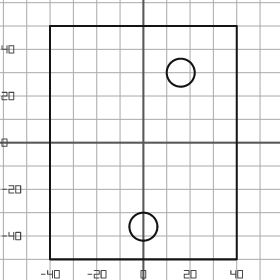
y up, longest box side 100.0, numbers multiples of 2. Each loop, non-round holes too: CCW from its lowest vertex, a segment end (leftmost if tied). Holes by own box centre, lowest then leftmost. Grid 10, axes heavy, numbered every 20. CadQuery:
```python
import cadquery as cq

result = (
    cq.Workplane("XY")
    .moveTo(-40.0, -50.0)
    .lineTo(40.0, -50.0)
    .lineTo(40.0, 50.0)
    .lineTo(-40.0, 50.0)
    .close()
    .moveTo(0.0, -36.0)
    .circle(6.0)
    .moveTo(16.0, 30.0)
    .circle(6.0)
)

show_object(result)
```